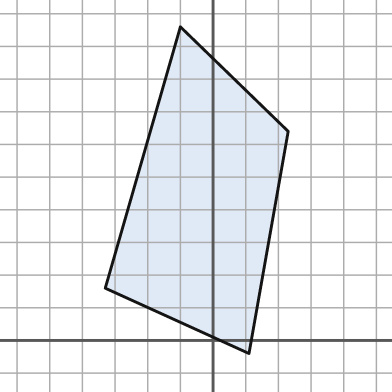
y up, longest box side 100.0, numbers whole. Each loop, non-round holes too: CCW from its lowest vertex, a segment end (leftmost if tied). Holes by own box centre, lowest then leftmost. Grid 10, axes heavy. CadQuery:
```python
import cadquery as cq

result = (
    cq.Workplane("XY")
    .moveTo(11.0, -4.0)
    .lineTo(23.0, 64.0)
    .lineTo(-10.0, 96.0)
    .lineTo(-33.0, 16.0)
    .close()
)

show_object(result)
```